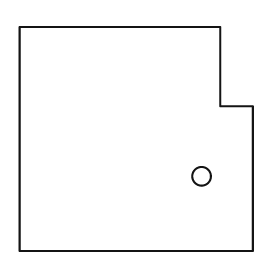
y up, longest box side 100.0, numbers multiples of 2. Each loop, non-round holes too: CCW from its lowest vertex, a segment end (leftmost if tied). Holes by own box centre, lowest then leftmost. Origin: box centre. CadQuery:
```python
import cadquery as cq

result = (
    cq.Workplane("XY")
    .moveTo(-50.0, -48.0)
    .lineTo(50.0, -48.0)
    .lineTo(50.0, 14.0)
    .lineTo(36.0, 14.0)
    .lineTo(36.0, 48.0)
    .lineTo(-50.0, 48.0)
    .close()
    .moveTo(28.0, -16.0)
    .circle(4.0)
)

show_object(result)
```